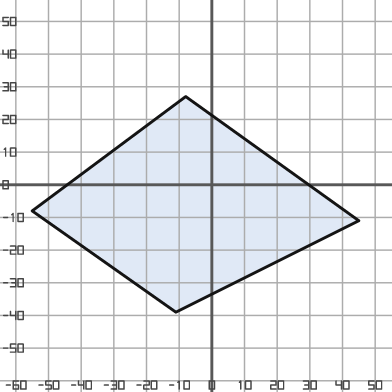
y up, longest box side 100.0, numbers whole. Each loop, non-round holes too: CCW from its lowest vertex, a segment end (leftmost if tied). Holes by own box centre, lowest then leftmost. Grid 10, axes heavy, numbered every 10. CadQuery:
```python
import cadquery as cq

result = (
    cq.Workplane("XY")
    .moveTo(-11.0, -39.0)
    .lineTo(45.0, -11.0)
    .lineTo(-8.0, 27.0)
    .lineTo(-55.0, -8.0)
    .close()
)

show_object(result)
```